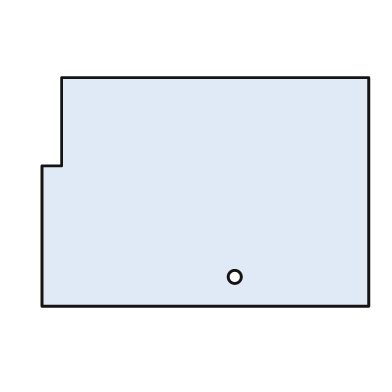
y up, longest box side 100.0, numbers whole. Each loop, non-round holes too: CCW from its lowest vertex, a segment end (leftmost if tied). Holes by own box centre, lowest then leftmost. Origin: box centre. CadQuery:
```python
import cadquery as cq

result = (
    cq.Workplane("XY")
    .moveTo(-50.0, -35.0)
    .lineTo(50.0, -35.0)
    .lineTo(50.0, 35.0)
    .lineTo(-44.0, 35.0)
    .lineTo(-44.0, 8.0)
    .lineTo(-50.0, 8.0)
    .close()
    .moveTo(9.0, -26.0)
    .circle(2.0)
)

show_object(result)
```